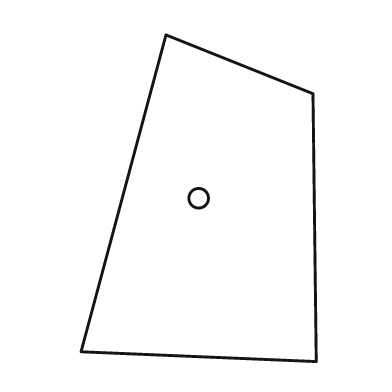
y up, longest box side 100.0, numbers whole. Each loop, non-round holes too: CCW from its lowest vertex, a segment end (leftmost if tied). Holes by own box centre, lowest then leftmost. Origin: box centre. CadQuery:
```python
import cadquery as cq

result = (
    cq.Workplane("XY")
    .moveTo(36.0, -50.0)
    .lineTo(35.0, 32.0)
    .lineTo(-10.0, 50.0)
    .lineTo(-36.0, -47.0)
    .close()
    .moveTo(0.0, 0.0)
    .circle(3.0)
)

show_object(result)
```